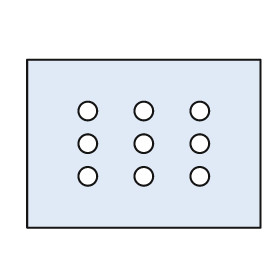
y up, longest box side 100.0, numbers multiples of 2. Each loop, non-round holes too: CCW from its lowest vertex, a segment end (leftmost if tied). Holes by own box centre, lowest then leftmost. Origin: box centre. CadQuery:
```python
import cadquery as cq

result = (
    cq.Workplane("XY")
    .moveTo(-50.0, -36.0)
    .lineTo(50.0, -36.0)
    .lineTo(50.0, 36.0)
    .lineTo(-50.0, 36.0)
    .close()
    .moveTo(-24.0, -14.0)
    .circle(4.0)
    .moveTo(0.0, -14.0)
    .circle(4.0)
    .moveTo(24.0, -14.0)
    .circle(4.0)
    .moveTo(-24.0, 0.0)
    .circle(4.0)
    .moveTo(0.0, 0.0)
    .circle(4.0)
    .moveTo(24.0, 0.0)
    .circle(4.0)
    .moveTo(-24.0, 14.0)
    .circle(4.0)
    .moveTo(0.0, 14.0)
    .circle(4.0)
    .moveTo(24.0, 14.0)
    .circle(4.0)
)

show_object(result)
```